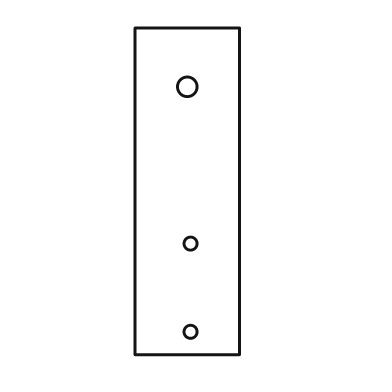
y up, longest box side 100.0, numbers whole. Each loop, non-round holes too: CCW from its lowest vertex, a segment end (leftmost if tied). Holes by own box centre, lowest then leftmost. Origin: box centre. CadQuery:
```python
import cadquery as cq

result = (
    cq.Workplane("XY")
    .moveTo(-16.0, -50.0)
    .lineTo(16.0, -50.0)
    .lineTo(16.0, 50.0)
    .lineTo(-16.0, 50.0)
    .close()
    .moveTo(1.0, -43.0)
    .circle(2.0)
    .moveTo(1.0, -16.0)
    .circle(2.0)
    .moveTo(0.0, 32.0)
    .circle(3.0)
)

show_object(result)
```